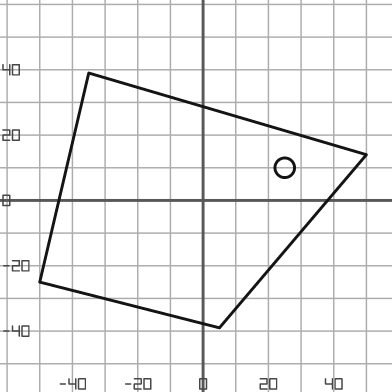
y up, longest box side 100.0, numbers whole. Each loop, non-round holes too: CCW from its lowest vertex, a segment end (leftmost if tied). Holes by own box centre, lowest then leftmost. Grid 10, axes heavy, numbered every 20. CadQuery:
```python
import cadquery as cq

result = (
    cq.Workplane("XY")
    .moveTo(5.0, -39.0)
    .lineTo(50.0, 14.0)
    .lineTo(-35.0, 39.0)
    .lineTo(-50.0, -25.0)
    .close()
    .moveTo(25.0, 10.0)
    .circle(3.0)
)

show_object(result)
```